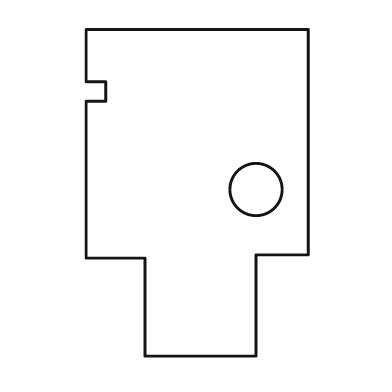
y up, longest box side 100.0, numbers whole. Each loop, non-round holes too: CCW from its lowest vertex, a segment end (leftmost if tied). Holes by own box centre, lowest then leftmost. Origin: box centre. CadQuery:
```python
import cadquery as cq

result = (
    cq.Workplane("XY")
    .moveTo(-16.0, -50.0)
    .lineTo(18.0, -50.0)
    .lineTo(18.0, -19.0)
    .lineTo(34.0, -19.0)
    .lineTo(34.0, 50.0)
    .lineTo(-34.0, 50.0)
    .lineTo(-34.0, 34.0)
    .lineTo(-28.0, 34.0)
    .lineTo(-28.0, 28.0)
    .lineTo(-34.0, 28.0)
    .lineTo(-34.0, -20.0)
    .lineTo(-16.0, -20.0)
    .close()
    .moveTo(18.0, 1.0)
    .circle(8.0)
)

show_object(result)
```